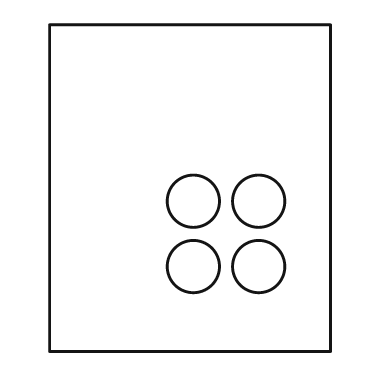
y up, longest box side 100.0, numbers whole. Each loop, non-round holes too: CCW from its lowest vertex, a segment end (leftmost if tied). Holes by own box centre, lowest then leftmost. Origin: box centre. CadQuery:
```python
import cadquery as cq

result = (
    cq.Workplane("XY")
    .moveTo(-43.0, -50.0)
    .lineTo(43.0, -50.0)
    .lineTo(43.0, 50.0)
    .lineTo(-43.0, 50.0)
    .close()
    .moveTo(1.0, -24.0)
    .circle(8.0)
    .moveTo(21.0, -24.0)
    .circle(8.0)
    .moveTo(1.0, -4.0)
    .circle(8.0)
    .moveTo(21.0, -4.0)
    .circle(8.0)
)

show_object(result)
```